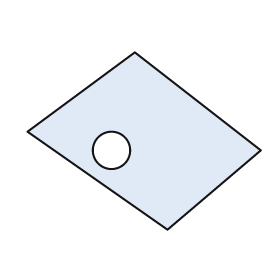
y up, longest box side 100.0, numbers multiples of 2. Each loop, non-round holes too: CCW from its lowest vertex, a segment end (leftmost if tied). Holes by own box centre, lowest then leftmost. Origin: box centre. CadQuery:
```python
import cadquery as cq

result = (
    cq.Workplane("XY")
    .moveTo(10.0, -38.0)
    .lineTo(50.0, -4.0)
    .lineTo(-4.0, 38.0)
    .lineTo(-50.0, 4.0)
    .close()
    .moveTo(-14.0, -4.0)
    .circle(8.0)
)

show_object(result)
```